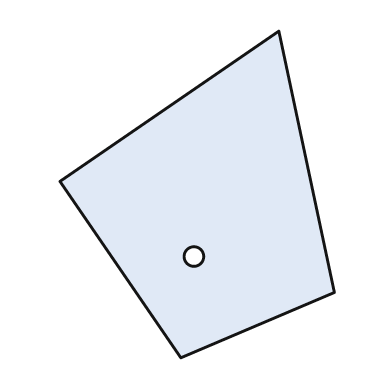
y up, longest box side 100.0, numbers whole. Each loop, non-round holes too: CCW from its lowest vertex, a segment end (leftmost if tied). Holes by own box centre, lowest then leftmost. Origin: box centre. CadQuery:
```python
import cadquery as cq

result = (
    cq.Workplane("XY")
    .moveTo(-5.0, -50.0)
    .lineTo(42.0, -30.0)
    .lineTo(25.0, 50.0)
    .lineTo(-42.0, 4.0)
    .close()
    .moveTo(-1.0, -19.0)
    .circle(3.0)
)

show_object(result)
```